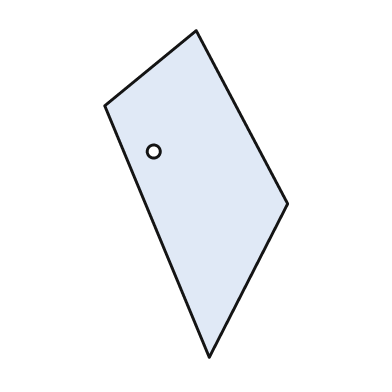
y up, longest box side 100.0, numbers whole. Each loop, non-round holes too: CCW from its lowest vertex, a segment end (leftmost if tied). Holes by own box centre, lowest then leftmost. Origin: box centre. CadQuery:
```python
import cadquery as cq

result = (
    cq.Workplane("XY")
    .moveTo(4.0, -50.0)
    .lineTo(28.0, -3.0)
    .lineTo(0.0, 50.0)
    .lineTo(-28.0, 27.0)
    .close()
    .moveTo(-13.0, 13.0)
    .circle(2.0)
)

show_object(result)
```